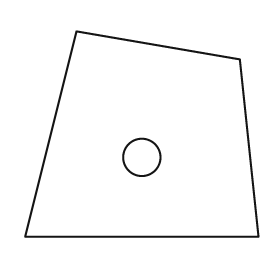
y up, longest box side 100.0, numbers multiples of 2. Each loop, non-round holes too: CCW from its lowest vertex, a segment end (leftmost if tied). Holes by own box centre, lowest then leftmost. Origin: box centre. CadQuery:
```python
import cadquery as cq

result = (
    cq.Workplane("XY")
    .moveTo(-50.0, -44.0)
    .lineTo(50.0, -44.0)
    .lineTo(42.0, 32.0)
    .lineTo(-28.0, 44.0)
    .close()
    .moveTo(0.0, -10.0)
    .circle(8.0)
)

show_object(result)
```